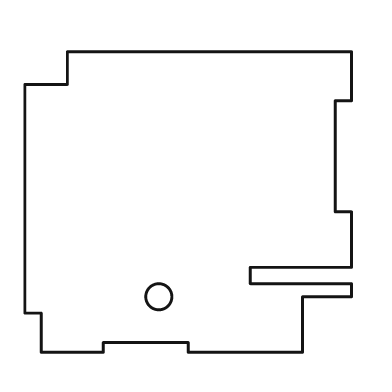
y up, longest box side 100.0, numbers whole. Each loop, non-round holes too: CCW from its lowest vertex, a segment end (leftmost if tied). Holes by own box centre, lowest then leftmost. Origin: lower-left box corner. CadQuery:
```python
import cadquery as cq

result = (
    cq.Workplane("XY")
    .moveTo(5.0, 0.0)
    .lineTo(24.0, 0.0)
    .lineTo(24.0, 3.0)
    .lineTo(50.0, 3.0)
    .lineTo(50.0, 0.0)
    .lineTo(85.0, 0.0)
    .lineTo(85.0, 17.0)
    .lineTo(100.0, 17.0)
    .lineTo(100.0, 21.0)
    .lineTo(69.0, 21.0)
    .lineTo(69.0, 26.0)
    .lineTo(100.0, 26.0)
    .lineTo(100.0, 43.0)
    .lineTo(95.0, 43.0)
    .lineTo(95.0, 77.0)
    .lineTo(100.0, 77.0)
    .lineTo(100.0, 92.0)
    .lineTo(13.0, 92.0)
    .lineTo(13.0, 82.0)
    .lineTo(0.0, 82.0)
    .lineTo(0.0, 12.0)
    .lineTo(5.0, 12.0)
    .close()
    .moveTo(41.0, 17.0)
    .circle(4.0)
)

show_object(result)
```